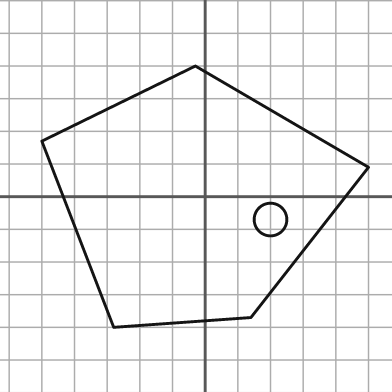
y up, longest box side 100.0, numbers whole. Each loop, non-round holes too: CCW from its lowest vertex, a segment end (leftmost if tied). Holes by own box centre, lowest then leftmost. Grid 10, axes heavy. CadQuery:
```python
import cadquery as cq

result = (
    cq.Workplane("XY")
    .moveTo(-28.0, -40.0)
    .lineTo(14.0, -37.0)
    .lineTo(50.0, 9.0)
    .lineTo(-3.0, 40.0)
    .lineTo(-50.0, 17.0)
    .close()
    .moveTo(20.0, -7.0)
    .circle(5.0)
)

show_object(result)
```